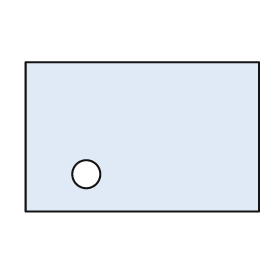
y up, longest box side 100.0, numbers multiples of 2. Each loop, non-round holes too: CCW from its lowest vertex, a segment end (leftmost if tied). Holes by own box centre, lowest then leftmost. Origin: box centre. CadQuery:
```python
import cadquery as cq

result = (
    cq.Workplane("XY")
    .moveTo(-50.0, -32.0)
    .lineTo(50.0, -32.0)
    .lineTo(50.0, 32.0)
    .lineTo(-50.0, 32.0)
    .close()
    .moveTo(-24.0, -16.0)
    .circle(6.0)
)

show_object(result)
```